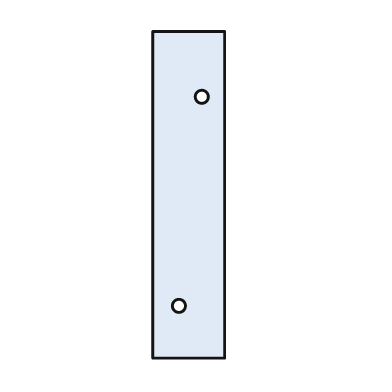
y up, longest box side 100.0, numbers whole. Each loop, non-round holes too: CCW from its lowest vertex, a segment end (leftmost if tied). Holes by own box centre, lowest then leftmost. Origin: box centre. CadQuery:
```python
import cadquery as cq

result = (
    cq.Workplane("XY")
    .moveTo(-11.0, -50.0)
    .lineTo(11.0, -50.0)
    .lineTo(11.0, 50.0)
    .lineTo(-11.0, 50.0)
    .close()
    .moveTo(-3.0, -34.0)
    .circle(2.0)
    .moveTo(4.0, 30.0)
    .circle(2.0)
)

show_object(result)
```